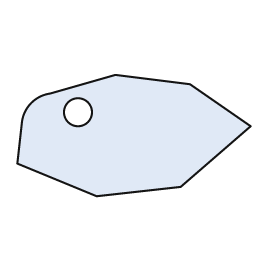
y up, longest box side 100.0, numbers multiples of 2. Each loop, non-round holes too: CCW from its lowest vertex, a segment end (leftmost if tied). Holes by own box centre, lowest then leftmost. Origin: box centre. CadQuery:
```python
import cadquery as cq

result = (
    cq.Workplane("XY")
    .moveTo(-16.0, -26.0)
    .lineTo(20.0, -22.0)
    .lineTo(50.0, 4.0)
    .lineTo(24.0, 22.0)
    .lineTo(-8.0, 26.0)
    .lineTo(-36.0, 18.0)
    .threePointArc((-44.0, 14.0), (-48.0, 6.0))
    .lineTo(-50.0, -12.0)
    .close()
    .moveTo(-24.0, 10.0)
    .circle(6.0)
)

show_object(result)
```